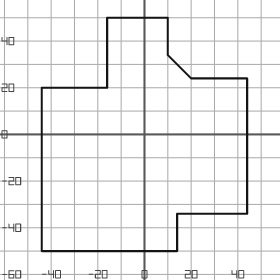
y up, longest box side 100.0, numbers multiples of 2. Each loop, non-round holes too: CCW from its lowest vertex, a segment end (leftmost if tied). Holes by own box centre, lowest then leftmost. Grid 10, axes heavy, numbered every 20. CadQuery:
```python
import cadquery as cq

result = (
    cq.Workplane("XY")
    .moveTo(-44.0, -50.0)
    .lineTo(14.0, -50.0)
    .lineTo(14.0, -34.0)
    .lineTo(44.0, -34.0)
    .lineTo(44.0, 24.0)
    .lineTo(20.0, 24.0)
    .lineTo(10.0, 34.0)
    .lineTo(10.0, 50.0)
    .lineTo(-16.0, 50.0)
    .lineTo(-16.0, 20.0)
    .lineTo(-44.0, 20.0)
    .close()
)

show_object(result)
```